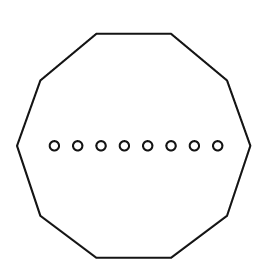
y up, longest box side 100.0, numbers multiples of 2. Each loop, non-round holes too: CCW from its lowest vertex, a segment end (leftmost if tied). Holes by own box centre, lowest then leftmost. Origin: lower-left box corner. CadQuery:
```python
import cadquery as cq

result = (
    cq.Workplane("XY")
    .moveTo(34.0, 0.0)
    .lineTo(66.0, 0.0)
    .lineTo(90.0, 18.0)
    .lineTo(100.0, 48.0)
    .lineTo(90.0, 76.0)
    .lineTo(66.0, 96.0)
    .lineTo(34.0, 96.0)
    .lineTo(10.0, 76.0)
    .lineTo(0.0, 48.0)
    .lineTo(10.0, 18.0)
    .close()
    .moveTo(16.0, 48.0)
    .circle(2.0)
    .moveTo(26.0, 48.0)
    .circle(2.0)
    .moveTo(36.0, 48.0)
    .circle(2.0)
    .moveTo(46.0, 48.0)
    .circle(2.0)
    .moveTo(56.0, 48.0)
    .circle(2.0)
    .moveTo(66.0, 48.0)
    .circle(2.0)
    .moveTo(76.0, 48.0)
    .circle(2.0)
    .moveTo(86.0, 48.0)
    .circle(2.0)
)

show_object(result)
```